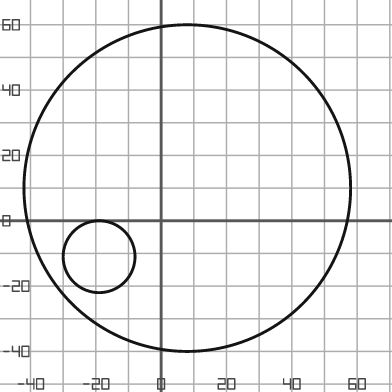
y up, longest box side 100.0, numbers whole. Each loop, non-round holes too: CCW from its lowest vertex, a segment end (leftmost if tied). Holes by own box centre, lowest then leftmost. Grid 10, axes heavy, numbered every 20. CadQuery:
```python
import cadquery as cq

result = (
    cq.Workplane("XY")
    .moveTo(8.0, 10.0)
    .circle(50.0)
    .moveTo(-19.0, -11.0)
    .circle(11.0)
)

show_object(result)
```